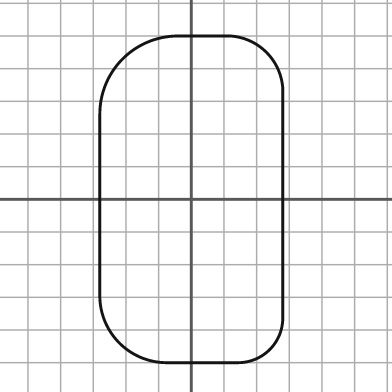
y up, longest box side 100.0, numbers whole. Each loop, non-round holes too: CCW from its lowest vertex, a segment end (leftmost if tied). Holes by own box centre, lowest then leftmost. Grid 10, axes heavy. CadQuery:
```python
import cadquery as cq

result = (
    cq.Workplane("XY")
    .moveTo(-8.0, -50.0)
    .lineTo(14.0, -50.0)
    .threePointArc((24.0, -46.0), (28.0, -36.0))
    .lineTo(28.0, 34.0)
    .threePointArc((23.0, 45.0), (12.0, 50.0))
    .lineTo(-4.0, 50.0)
    .threePointArc((-21.0, 43.0), (-28.0, 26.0))
    .lineTo(-28.0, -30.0)
    .threePointArc((-22.0, -44.0), (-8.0, -50.0))
    .close()
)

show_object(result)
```